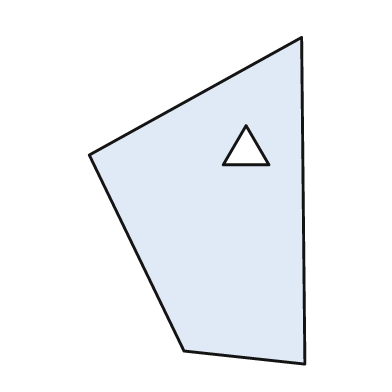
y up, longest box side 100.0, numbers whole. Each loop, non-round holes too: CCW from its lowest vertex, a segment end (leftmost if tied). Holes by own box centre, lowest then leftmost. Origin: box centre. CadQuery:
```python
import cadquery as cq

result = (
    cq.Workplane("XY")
    .moveTo(33.0, -50.0)
    .lineTo(32.0, 50.0)
    .lineTo(-33.0, 14.0)
    .lineTo(-4.0, -46.0)
    .close()
    .moveTo(8.0, 11.0)
    .lineTo(22.0, 11.0)
    .lineTo(15.0, 23.0)
    .close()
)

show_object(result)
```